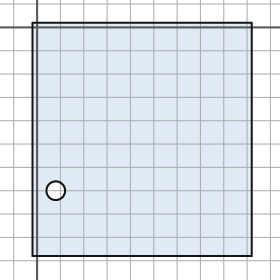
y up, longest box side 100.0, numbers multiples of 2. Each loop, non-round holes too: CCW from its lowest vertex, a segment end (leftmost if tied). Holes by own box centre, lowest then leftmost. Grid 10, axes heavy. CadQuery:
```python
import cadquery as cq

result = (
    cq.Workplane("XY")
    .moveTo(-2.0, -98.0)
    .lineTo(92.0, -98.0)
    .lineTo(92.0, 2.0)
    .lineTo(-2.0, 2.0)
    .close()
    .moveTo(8.0, -70.0)
    .circle(4.0)
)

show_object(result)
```